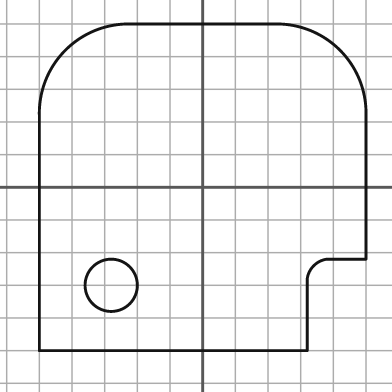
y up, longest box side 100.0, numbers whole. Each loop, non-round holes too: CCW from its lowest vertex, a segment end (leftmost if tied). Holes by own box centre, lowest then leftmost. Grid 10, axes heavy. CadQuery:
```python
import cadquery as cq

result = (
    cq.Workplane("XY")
    .moveTo(-50.0, -50.0)
    .lineTo(32.0, -50.0)
    .lineTo(32.0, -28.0)
    .threePointArc((34.0, -24.0), (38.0, -22.0))
    .lineTo(50.0, -22.0)
    .lineTo(50.0, 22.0)
    .threePointArc((42.0, 42.0), (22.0, 50.0))
    .lineTo(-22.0, 50.0)
    .threePointArc((-42.0, 42.0), (-50.0, 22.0))
    .close()
    .moveTo(-28.0, -30.0)
    .circle(8.0)
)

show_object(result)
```